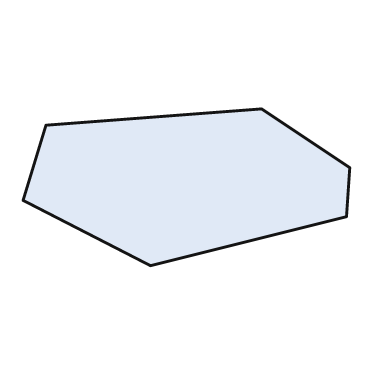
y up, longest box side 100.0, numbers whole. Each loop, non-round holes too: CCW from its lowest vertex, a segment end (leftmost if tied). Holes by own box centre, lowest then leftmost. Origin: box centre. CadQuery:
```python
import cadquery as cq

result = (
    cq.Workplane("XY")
    .moveTo(-11.0, -24.0)
    .lineTo(49.0, -9.0)
    .lineTo(50.0, 6.0)
    .lineTo(23.0, 24.0)
    .lineTo(-43.0, 19.0)
    .lineTo(-50.0, -4.0)
    .close()
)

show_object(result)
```